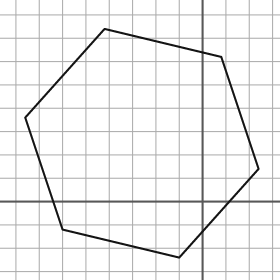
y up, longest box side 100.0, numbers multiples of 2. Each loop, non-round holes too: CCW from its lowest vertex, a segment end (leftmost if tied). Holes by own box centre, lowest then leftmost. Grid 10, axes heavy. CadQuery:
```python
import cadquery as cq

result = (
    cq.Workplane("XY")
    .moveTo(-10.0, -24.0)
    .lineTo(24.0, 14.0)
    .lineTo(8.0, 62.0)
    .lineTo(-42.0, 74.0)
    .lineTo(-76.0, 36.0)
    .lineTo(-60.0, -12.0)
    .close()
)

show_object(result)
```